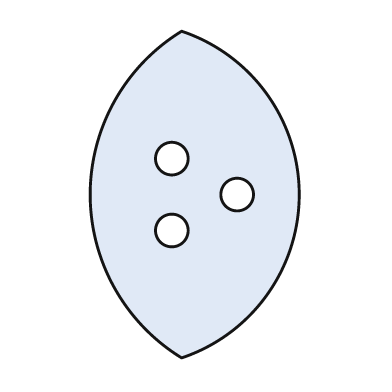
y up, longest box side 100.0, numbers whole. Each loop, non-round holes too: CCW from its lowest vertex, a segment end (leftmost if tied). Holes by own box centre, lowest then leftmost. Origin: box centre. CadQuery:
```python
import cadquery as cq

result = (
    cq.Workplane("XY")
    .moveTo(-4.0, -50.0)
    .threePointArc((32.0, 0.0), (-4.0, 50.0))
    .threePointArc((-32.0, 0.0), (-4.0, -50.0))
    .close()
    .moveTo(-7.0, -11.0)
    .circle(5.0)
    .moveTo(13.0, 0.0)
    .circle(5.0)
    .moveTo(-7.0, 11.0)
    .circle(5.0)
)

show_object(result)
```